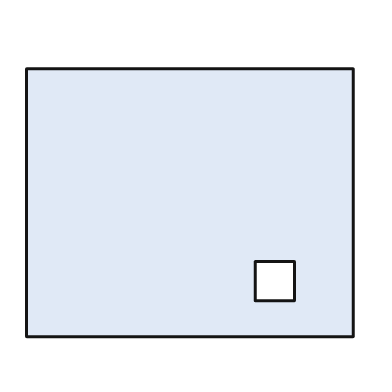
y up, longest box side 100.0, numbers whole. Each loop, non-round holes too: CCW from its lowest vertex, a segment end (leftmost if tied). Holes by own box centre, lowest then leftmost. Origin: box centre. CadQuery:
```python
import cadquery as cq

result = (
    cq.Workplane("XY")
    .moveTo(-50.0, -41.0)
    .lineTo(50.0, -41.0)
    .lineTo(50.0, 41.0)
    .lineTo(-50.0, 41.0)
    .close()
    .moveTo(20.0, -30.0)
    .lineTo(32.0, -30.0)
    .lineTo(32.0, -18.0)
    .lineTo(20.0, -18.0)
    .close()
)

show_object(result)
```